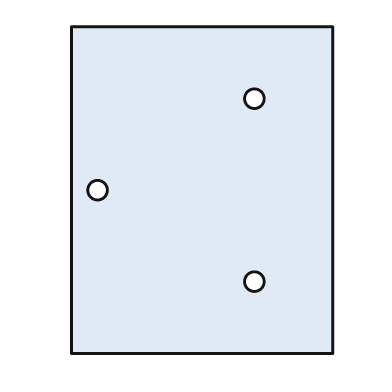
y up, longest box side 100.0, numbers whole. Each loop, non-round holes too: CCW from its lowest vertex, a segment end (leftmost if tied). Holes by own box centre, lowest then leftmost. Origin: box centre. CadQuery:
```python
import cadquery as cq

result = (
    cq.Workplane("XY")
    .moveTo(-40.0, -50.0)
    .lineTo(40.0, -50.0)
    .lineTo(40.0, 50.0)
    .lineTo(-40.0, 50.0)
    .close()
    .moveTo(16.0, -28.0)
    .circle(3.0)
    .moveTo(-32.0, 0.0)
    .circle(3.0)
    .moveTo(16.0, 28.0)
    .circle(3.0)
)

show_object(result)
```